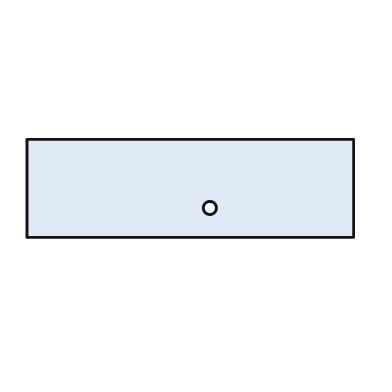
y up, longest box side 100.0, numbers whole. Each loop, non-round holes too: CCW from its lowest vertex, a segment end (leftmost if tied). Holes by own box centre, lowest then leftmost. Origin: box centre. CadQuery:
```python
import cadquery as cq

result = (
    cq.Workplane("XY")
    .moveTo(-50.0, -15.0)
    .lineTo(50.0, -15.0)
    .lineTo(50.0, 15.0)
    .lineTo(-50.0, 15.0)
    .close()
    .moveTo(6.0, -6.0)
    .circle(2.0)
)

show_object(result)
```